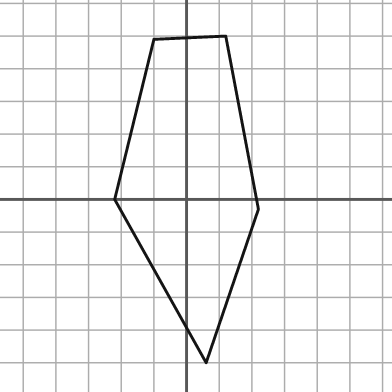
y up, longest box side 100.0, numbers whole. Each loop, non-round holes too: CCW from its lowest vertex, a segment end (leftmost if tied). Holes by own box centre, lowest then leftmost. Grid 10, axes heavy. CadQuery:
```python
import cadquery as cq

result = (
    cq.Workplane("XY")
    .moveTo(6.0, -50.0)
    .lineTo(22.0, -3.0)
    .lineTo(12.0, 50.0)
    .lineTo(-10.0, 49.0)
    .lineTo(-22.0, 0.0)
    .close()
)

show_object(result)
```